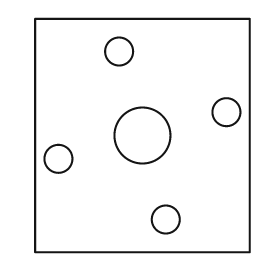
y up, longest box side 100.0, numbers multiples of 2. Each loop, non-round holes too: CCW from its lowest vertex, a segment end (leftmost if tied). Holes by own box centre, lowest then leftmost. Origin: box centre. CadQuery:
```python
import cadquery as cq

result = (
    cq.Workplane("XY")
    .moveTo(-46.0, -50.0)
    .lineTo(46.0, -50.0)
    .lineTo(46.0, 50.0)
    .lineTo(-46.0, 50.0)
    .close()
    .moveTo(10.0, -36.0)
    .circle(6.0)
    .moveTo(-36.0, -10.0)
    .circle(6.0)
    .moveTo(0.0, 0.0)
    .circle(12.0)
    .moveTo(36.0, 10.0)
    .circle(6.0)
    .moveTo(-10.0, 36.0)
    .circle(6.0)
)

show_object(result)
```